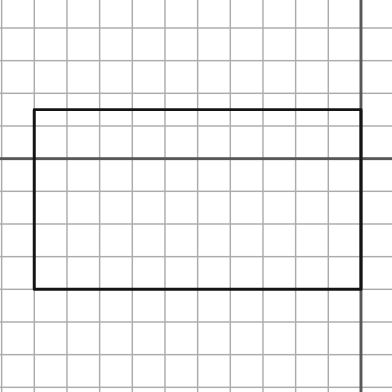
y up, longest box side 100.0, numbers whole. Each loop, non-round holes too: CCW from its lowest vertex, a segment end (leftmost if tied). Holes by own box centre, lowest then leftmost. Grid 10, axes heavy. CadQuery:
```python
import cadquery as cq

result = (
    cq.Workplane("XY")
    .moveTo(-100.0, -40.0)
    .lineTo(0.0, -40.0)
    .lineTo(0.0, 15.0)
    .lineTo(-100.0, 15.0)
    .close()
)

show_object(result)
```